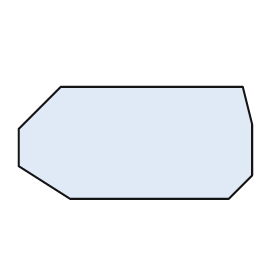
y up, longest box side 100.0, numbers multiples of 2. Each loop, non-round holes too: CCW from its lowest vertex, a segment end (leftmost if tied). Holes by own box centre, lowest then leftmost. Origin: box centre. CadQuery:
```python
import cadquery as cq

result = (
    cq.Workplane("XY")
    .moveTo(-28.0, -24.0)
    .lineTo(40.0, -24.0)
    .lineTo(50.0, -14.0)
    .lineTo(50.0, 8.0)
    .lineTo(46.0, 24.0)
    .lineTo(-32.0, 24.0)
    .lineTo(-50.0, 6.0)
    .lineTo(-50.0, -10.0)
    .close()
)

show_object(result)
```